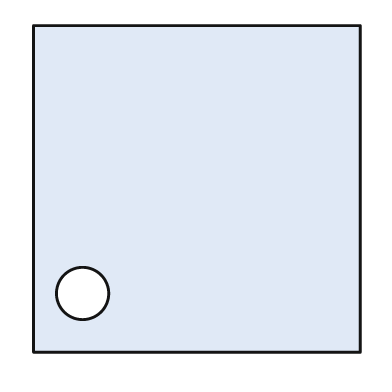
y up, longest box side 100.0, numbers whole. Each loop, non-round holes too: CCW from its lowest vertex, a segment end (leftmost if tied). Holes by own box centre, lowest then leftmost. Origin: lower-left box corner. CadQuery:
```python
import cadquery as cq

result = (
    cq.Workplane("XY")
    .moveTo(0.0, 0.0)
    .lineTo(100.0, 0.0)
    .lineTo(100.0, 100.0)
    .lineTo(0.0, 100.0)
    .close()
    .moveTo(15.0, 18.0)
    .circle(8.0)
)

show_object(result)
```